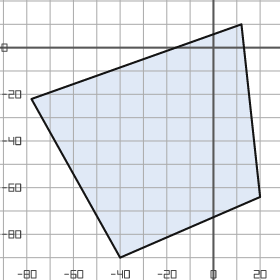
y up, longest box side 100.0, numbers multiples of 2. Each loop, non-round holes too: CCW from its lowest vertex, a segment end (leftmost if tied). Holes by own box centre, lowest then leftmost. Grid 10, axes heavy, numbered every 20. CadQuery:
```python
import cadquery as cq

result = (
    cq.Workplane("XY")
    .moveTo(-40.0, -90.0)
    .lineTo(20.0, -64.0)
    .lineTo(12.0, 10.0)
    .lineTo(-78.0, -22.0)
    .close()
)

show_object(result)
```